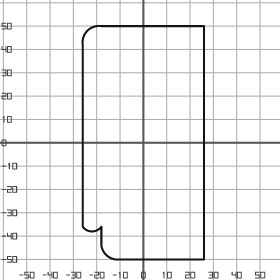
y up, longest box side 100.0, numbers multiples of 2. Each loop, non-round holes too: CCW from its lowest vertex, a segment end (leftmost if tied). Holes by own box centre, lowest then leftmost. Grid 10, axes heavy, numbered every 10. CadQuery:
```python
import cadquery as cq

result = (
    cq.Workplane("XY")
    .moveTo(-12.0, -50.0)
    .lineTo(26.0, -50.0)
    .lineTo(26.0, 50.0)
    .lineTo(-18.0, 50.0)
    .threePointArc((-24.0, 48.0), (-26.0, 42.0))
    .lineTo(-26.0, -36.0)
    .threePointArc((-22.0, -38.0), (-18.0, -36.0))
    .lineTo(-18.0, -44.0)
    .threePointArc((-16.0, -48.0), (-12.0, -50.0))
    .close()
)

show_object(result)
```